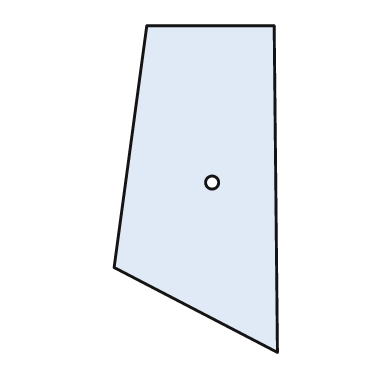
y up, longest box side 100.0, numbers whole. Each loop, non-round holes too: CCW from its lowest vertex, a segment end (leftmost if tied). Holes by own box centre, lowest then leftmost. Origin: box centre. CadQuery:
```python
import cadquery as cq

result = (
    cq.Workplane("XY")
    .moveTo(25.0, -50.0)
    .lineTo(24.0, 50.0)
    .lineTo(-15.0, 50.0)
    .lineTo(-25.0, -24.0)
    .close()
    .moveTo(5.0, 2.0)
    .circle(2.0)
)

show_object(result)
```